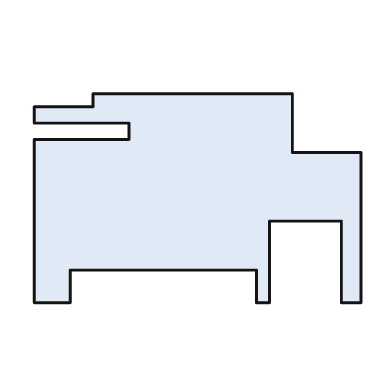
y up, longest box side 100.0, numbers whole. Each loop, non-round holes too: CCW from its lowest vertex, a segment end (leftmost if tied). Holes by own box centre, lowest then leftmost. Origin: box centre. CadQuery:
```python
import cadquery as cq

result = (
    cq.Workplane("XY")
    .moveTo(-50.0, -32.0)
    .lineTo(-39.0, -32.0)
    .lineTo(-39.0, -22.0)
    .lineTo(18.0, -22.0)
    .lineTo(18.0, -32.0)
    .lineTo(22.0, -32.0)
    .lineTo(22.0, -7.0)
    .lineTo(44.0, -7.0)
    .lineTo(44.0, -32.0)
    .lineTo(50.0, -32.0)
    .lineTo(50.0, 14.0)
    .lineTo(29.0, 14.0)
    .lineTo(29.0, 32.0)
    .lineTo(-32.0, 32.0)
    .lineTo(-32.0, 28.0)
    .lineTo(-50.0, 28.0)
    .lineTo(-50.0, 23.0)
    .lineTo(-21.0, 23.0)
    .lineTo(-21.0, 18.0)
    .lineTo(-50.0, 18.0)
    .close()
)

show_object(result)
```